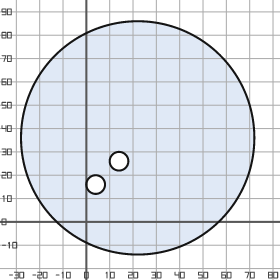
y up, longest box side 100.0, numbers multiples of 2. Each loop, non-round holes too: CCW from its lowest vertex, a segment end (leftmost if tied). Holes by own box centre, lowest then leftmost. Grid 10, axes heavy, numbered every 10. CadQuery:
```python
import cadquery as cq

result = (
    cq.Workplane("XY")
    .moveTo(22.0, 36.0)
    .circle(50.0)
    .moveTo(4.0, 16.0)
    .circle(4.0)
    .moveTo(14.0, 26.0)
    .circle(4.0)
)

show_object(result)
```